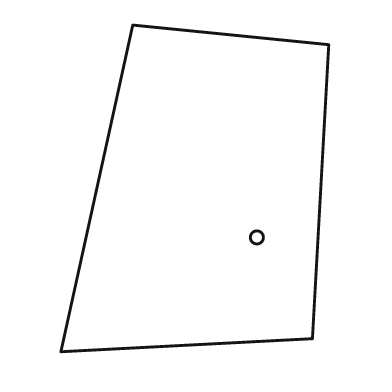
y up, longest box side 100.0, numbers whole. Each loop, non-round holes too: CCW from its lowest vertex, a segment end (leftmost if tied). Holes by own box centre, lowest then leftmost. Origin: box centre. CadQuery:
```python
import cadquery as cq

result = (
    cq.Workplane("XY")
    .moveTo(-41.0, -50.0)
    .lineTo(36.0, -46.0)
    .lineTo(41.0, 44.0)
    .lineTo(-19.0, 50.0)
    .close()
    .moveTo(19.0, -15.0)
    .circle(2.0)
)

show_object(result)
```